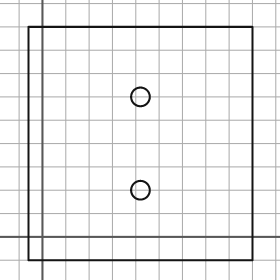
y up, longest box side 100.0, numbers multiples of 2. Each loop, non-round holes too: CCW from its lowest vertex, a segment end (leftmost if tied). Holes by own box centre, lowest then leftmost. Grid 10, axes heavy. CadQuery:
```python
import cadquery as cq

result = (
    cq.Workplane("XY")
    .moveTo(-6.0, -10.0)
    .lineTo(90.0, -10.0)
    .lineTo(90.0, 90.0)
    .lineTo(-6.0, 90.0)
    .close()
    .moveTo(42.0, 20.0)
    .circle(4.0)
    .moveTo(42.0, 60.0)
    .circle(4.0)
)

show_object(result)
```